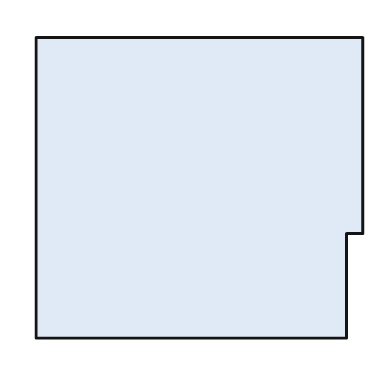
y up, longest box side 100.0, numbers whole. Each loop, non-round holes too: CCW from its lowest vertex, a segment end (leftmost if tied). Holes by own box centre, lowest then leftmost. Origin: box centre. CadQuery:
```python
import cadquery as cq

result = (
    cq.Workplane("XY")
    .moveTo(-50.0, -46.0)
    .lineTo(45.0, -46.0)
    .lineTo(45.0, -14.0)
    .lineTo(50.0, -14.0)
    .lineTo(50.0, 46.0)
    .lineTo(-50.0, 46.0)
    .close()
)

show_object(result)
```